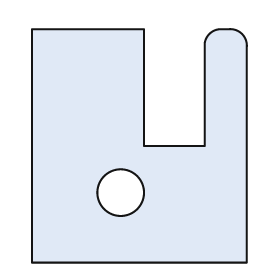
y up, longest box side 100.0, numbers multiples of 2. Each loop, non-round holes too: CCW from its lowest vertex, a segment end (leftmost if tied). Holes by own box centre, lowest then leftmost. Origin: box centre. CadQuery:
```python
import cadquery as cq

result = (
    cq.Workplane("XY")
    .moveTo(-46.0, -50.0)
    .lineTo(46.0, -50.0)
    .lineTo(46.0, 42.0)
    .threePointArc((44.0, 48.0), (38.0, 50.0))
    .lineTo(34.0, 50.0)
    .threePointArc((30.0, 48.0), (28.0, 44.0))
    .lineTo(28.0, 0.0)
    .lineTo(2.0, 0.0)
    .lineTo(2.0, 50.0)
    .lineTo(-46.0, 50.0)
    .close()
    .moveTo(-8.0, -20.0)
    .circle(10.0)
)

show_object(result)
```